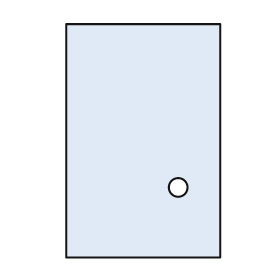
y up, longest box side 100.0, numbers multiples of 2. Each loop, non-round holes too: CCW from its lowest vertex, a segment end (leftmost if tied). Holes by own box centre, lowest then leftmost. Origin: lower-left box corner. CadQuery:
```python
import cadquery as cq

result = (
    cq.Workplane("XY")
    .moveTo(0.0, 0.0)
    .lineTo(66.0, 0.0)
    .lineTo(66.0, 100.0)
    .lineTo(0.0, 100.0)
    .close()
    .moveTo(48.0, 30.0)
    .circle(4.0)
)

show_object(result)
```